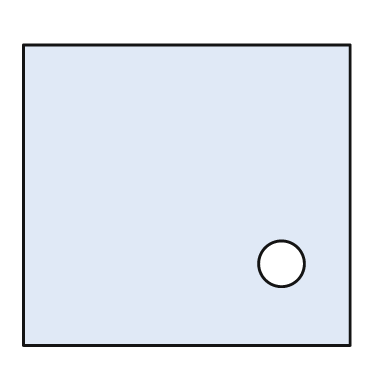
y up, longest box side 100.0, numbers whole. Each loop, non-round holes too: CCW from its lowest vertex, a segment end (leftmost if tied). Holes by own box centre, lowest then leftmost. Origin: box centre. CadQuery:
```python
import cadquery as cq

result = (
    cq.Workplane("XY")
    .moveTo(-50.0, -46.0)
    .lineTo(50.0, -46.0)
    .lineTo(50.0, 46.0)
    .lineTo(-50.0, 46.0)
    .close()
    .moveTo(29.0, -21.0)
    .circle(7.0)
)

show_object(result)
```